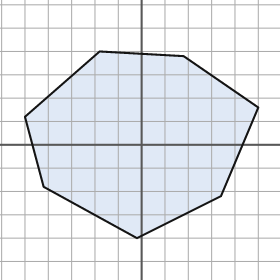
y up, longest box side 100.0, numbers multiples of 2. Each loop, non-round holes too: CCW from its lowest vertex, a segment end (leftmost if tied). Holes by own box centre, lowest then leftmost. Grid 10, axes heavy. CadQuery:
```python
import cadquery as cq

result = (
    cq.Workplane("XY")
    .moveTo(-2.0, -40.0)
    .lineTo(34.0, -22.0)
    .lineTo(50.0, 16.0)
    .lineTo(18.0, 38.0)
    .lineTo(-18.0, 40.0)
    .lineTo(-50.0, 12.0)
    .lineTo(-42.0, -18.0)
    .close()
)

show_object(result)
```